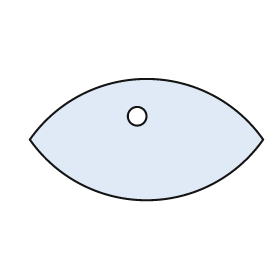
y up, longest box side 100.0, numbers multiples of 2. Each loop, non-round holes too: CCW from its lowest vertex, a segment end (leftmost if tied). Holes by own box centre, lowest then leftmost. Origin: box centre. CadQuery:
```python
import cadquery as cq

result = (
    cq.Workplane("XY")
    .moveTo(-50.0, 0.0)
    .threePointArc((0.0, -26.0), (50.0, 0.0))
    .threePointArc((0.0, 26.0), (-50.0, 0.0))
    .close()
    .moveTo(-4.0, 10.0)
    .circle(4.0)
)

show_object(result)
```